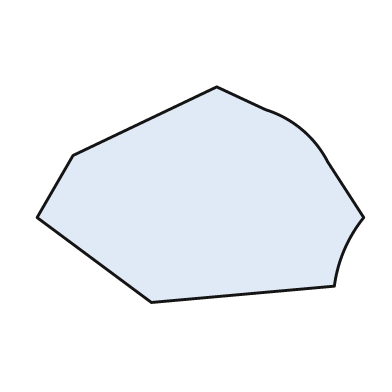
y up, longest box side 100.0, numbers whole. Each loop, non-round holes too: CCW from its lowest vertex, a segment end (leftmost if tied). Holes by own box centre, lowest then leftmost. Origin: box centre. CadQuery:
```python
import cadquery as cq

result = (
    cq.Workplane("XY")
    .moveTo(-15.0, -33.0)
    .lineTo(41.0, -28.0)
    .threePointArc((44.0, -17.0), (50.0, -7.0))
    .lineTo(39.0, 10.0)
    .threePointArc((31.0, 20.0), (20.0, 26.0))
    .lineTo(5.0, 33.0)
    .lineTo(-39.0, 12.0)
    .lineTo(-50.0, -7.0)
    .close()
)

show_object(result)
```